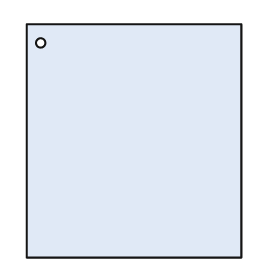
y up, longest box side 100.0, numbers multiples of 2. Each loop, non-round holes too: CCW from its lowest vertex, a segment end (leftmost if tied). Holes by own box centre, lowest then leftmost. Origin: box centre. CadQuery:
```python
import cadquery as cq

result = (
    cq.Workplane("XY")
    .moveTo(-46.0, -50.0)
    .lineTo(46.0, -50.0)
    .lineTo(46.0, 50.0)
    .lineTo(-46.0, 50.0)
    .close()
    .moveTo(-40.0, 42.0)
    .circle(2.0)
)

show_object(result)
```